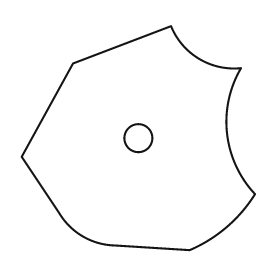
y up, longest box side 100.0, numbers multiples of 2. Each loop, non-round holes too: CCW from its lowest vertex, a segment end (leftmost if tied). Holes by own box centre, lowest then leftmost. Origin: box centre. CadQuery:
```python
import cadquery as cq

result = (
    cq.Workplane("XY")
    .moveTo(22.0, -48.0)
    .threePointArc((38.0, -38.0), (50.0, -24.0))
    .threePointArc((38.0, 2.0), (44.0, 30.0))
    .threePointArc((26.0, 34.0), (14.0, 48.0))
    .lineTo(-28.0, 32.0)
    .lineTo(-50.0, -8.0)
    .lineTo(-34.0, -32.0)
    .threePointArc((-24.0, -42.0), (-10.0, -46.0))
    .close()
    .moveTo(0.0, 0.0)
    .circle(6.0)
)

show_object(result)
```